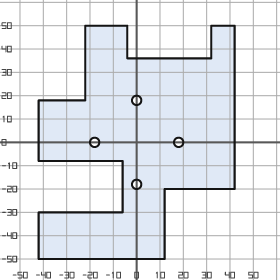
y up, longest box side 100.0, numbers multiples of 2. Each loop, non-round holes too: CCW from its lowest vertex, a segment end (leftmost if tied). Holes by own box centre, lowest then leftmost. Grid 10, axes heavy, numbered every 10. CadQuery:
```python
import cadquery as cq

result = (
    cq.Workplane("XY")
    .moveTo(-42.0, -50.0)
    .lineTo(12.0, -50.0)
    .lineTo(12.0, -20.0)
    .lineTo(42.0, -20.0)
    .lineTo(42.0, 50.0)
    .lineTo(32.0, 50.0)
    .lineTo(32.0, 36.0)
    .lineTo(-4.0, 36.0)
    .lineTo(-4.0, 50.0)
    .lineTo(-22.0, 50.0)
    .lineTo(-22.0, 18.0)
    .lineTo(-42.0, 18.0)
    .lineTo(-42.0, -8.0)
    .lineTo(-6.0, -8.0)
    .lineTo(-6.0, -30.0)
    .lineTo(-42.0, -30.0)
    .close()
    .moveTo(0.0, -18.0)
    .circle(2.0)
    .moveTo(-18.0, 0.0)
    .circle(2.0)
    .moveTo(18.0, 0.0)
    .circle(2.0)
    .moveTo(0.0, 18.0)
    .circle(2.0)
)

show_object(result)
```